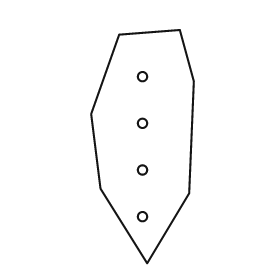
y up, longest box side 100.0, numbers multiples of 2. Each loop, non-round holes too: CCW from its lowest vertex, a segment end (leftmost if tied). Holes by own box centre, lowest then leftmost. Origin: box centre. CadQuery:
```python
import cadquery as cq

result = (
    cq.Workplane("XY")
    .moveTo(2.0, -50.0)
    .lineTo(20.0, -20.0)
    .lineTo(22.0, 28.0)
    .lineTo(16.0, 50.0)
    .lineTo(-10.0, 48.0)
    .lineTo(-22.0, 14.0)
    .lineTo(-18.0, -18.0)
    .close()
    .moveTo(0.0, -30.0)
    .circle(2.0)
    .moveTo(0.0, -10.0)
    .circle(2.0)
    .moveTo(0.0, 10.0)
    .circle(2.0)
    .moveTo(0.0, 30.0)
    .circle(2.0)
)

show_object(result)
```